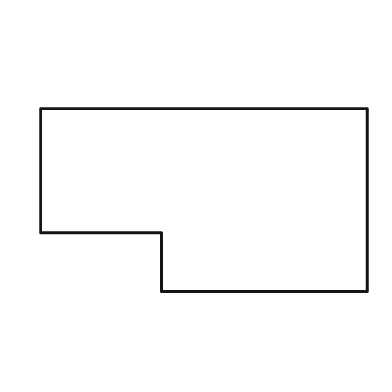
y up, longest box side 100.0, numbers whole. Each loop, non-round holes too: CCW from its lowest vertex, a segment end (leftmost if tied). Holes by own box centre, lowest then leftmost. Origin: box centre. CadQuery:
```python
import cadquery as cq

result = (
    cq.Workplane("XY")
    .moveTo(-13.0, -28.0)
    .lineTo(50.0, -28.0)
    .lineTo(50.0, 28.0)
    .lineTo(-50.0, 28.0)
    .lineTo(-50.0, -10.0)
    .lineTo(-13.0, -10.0)
    .close()
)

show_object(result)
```